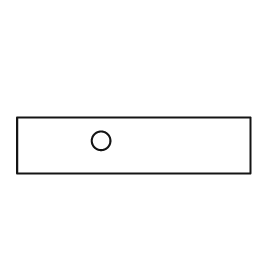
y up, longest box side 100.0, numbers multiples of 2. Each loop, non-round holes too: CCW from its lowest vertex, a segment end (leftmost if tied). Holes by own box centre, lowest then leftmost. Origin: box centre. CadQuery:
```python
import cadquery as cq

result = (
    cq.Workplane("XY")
    .moveTo(-50.0, -12.0)
    .lineTo(50.0, -12.0)
    .lineTo(50.0, 12.0)
    .lineTo(-50.0, 12.0)
    .close()
    .moveTo(-14.0, 2.0)
    .circle(4.0)
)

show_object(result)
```